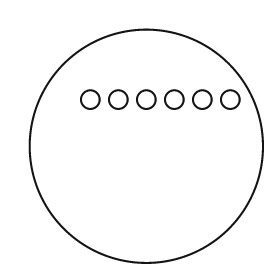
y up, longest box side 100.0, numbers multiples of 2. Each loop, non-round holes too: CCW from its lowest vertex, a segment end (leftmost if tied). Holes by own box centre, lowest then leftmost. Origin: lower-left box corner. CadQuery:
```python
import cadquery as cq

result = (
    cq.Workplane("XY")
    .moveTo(50.0, 50.0)
    .circle(50.0)
    .moveTo(26.0, 70.0)
    .circle(4.0)
    .moveTo(38.0, 70.0)
    .circle(4.0)
    .moveTo(50.0, 70.0)
    .circle(4.0)
    .moveTo(62.0, 70.0)
    .circle(4.0)
    .moveTo(74.0, 70.0)
    .circle(4.0)
    .moveTo(86.0, 70.0)
    .circle(4.0)
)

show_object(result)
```